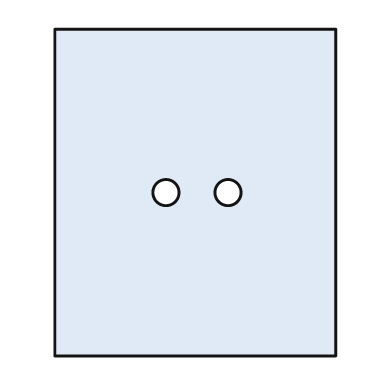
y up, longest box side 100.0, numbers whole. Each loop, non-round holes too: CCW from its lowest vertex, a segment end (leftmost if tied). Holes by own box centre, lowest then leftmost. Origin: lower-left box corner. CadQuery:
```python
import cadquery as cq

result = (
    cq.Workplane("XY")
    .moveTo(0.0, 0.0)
    .lineTo(86.0, 0.0)
    .lineTo(86.0, 100.0)
    .lineTo(0.0, 100.0)
    .close()
    .moveTo(34.0, 50.0)
    .circle(4.0)
    .moveTo(53.0, 50.0)
    .circle(4.0)
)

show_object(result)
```